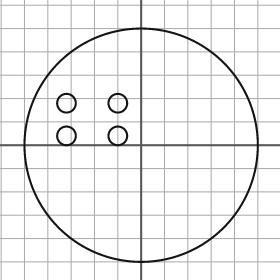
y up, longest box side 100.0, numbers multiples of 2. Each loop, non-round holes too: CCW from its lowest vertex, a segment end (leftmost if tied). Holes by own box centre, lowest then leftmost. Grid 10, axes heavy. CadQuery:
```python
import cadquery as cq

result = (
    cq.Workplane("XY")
    .moveTo(0.0, 0.0)
    .circle(50.0)
    .moveTo(-32.0, 4.0)
    .circle(4.0)
    .moveTo(-10.0, 4.0)
    .circle(4.0)
    .moveTo(-32.0, 18.0)
    .circle(4.0)
    .moveTo(-10.0, 18.0)
    .circle(4.0)
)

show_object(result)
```